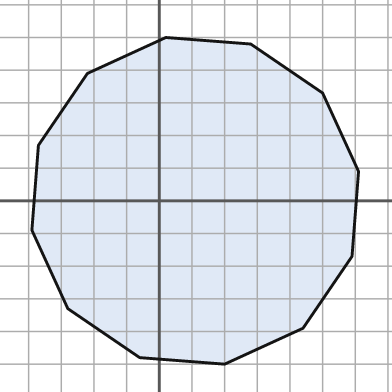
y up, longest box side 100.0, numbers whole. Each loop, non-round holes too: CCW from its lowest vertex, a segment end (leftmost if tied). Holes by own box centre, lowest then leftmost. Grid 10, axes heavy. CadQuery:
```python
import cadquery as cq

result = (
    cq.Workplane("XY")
    .moveTo(20.0, -50.0)
    .lineTo(44.0, -39.0)
    .lineTo(59.0, -17.0)
    .lineTo(61.0, 9.0)
    .lineTo(50.0, 33.0)
    .lineTo(28.0, 48.0)
    .lineTo(2.0, 50.0)
    .lineTo(-22.0, 39.0)
    .lineTo(-37.0, 17.0)
    .lineTo(-39.0, -9.0)
    .lineTo(-28.0, -33.0)
    .lineTo(-6.0, -48.0)
    .close()
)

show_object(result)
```